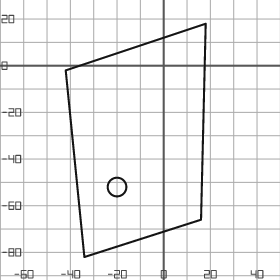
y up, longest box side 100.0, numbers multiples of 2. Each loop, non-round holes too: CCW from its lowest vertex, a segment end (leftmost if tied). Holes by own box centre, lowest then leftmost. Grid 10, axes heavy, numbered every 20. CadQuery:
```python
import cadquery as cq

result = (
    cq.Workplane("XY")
    .moveTo(-34.0, -82.0)
    .lineTo(16.0, -66.0)
    .lineTo(18.0, 18.0)
    .lineTo(-42.0, -2.0)
    .close()
    .moveTo(-20.0, -52.0)
    .circle(4.0)
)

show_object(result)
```